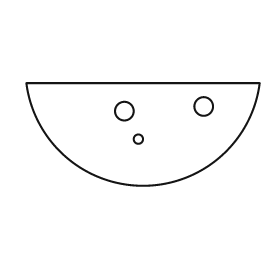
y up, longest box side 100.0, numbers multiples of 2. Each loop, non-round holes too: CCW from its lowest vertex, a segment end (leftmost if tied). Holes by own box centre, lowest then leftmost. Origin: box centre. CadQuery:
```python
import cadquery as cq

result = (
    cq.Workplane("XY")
    .moveTo(-50.0, 22.0)
    .threePointArc((0.0, -22.0), (50.0, 22.0))
    .close()
    .moveTo(-2.0, -2.0)
    .circle(2.0)
    .moveTo(-8.0, 10.0)
    .circle(4.0)
    .moveTo(26.0, 12.0)
    .circle(4.0)
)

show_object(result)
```